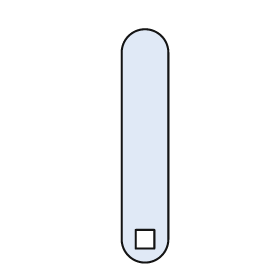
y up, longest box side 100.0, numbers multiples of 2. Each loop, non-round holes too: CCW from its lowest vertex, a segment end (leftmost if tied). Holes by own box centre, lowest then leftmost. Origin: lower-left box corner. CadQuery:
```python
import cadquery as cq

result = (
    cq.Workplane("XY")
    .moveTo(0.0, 10.0)
    .threePointArc((10.0, 0.0), (20.0, 10.0))
    .lineTo(20.0, 90.0)
    .threePointArc((10.0, 100.0), (0.0, 90.0))
    .close()
    .moveTo(6.0, 6.0)
    .lineTo(14.0, 6.0)
    .lineTo(14.0, 14.0)
    .lineTo(6.0, 14.0)
    .close()
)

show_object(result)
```